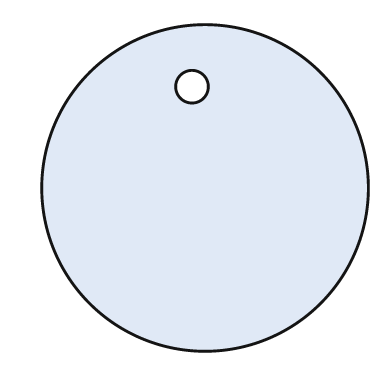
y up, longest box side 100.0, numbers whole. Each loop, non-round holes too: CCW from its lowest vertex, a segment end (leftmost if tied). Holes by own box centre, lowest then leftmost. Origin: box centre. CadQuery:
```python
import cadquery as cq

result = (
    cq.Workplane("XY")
    .moveTo(0.0, 0.0)
    .circle(50.0)
    .moveTo(-4.0, 31.0)
    .circle(5.0)
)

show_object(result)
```